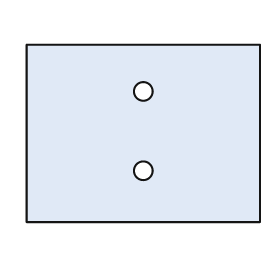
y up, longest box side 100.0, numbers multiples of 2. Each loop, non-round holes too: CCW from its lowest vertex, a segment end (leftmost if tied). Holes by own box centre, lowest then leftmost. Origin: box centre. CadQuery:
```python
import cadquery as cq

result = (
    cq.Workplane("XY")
    .moveTo(-50.0, -38.0)
    .lineTo(50.0, -38.0)
    .lineTo(50.0, 38.0)
    .lineTo(-50.0, 38.0)
    .close()
    .moveTo(0.0, -16.0)
    .circle(4.0)
    .moveTo(0.0, 18.0)
    .circle(4.0)
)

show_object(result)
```